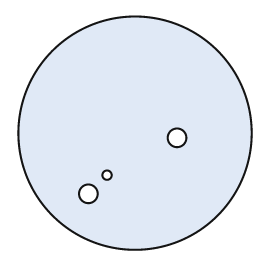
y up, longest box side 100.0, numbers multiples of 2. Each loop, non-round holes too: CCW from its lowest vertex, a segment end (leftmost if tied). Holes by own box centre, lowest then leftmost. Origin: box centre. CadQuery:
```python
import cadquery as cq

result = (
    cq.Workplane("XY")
    .moveTo(0.0, 0.0)
    .circle(50.0)
    .moveTo(-20.0, -26.0)
    .circle(4.0)
    .moveTo(-12.0, -18.0)
    .circle(2.0)
    .moveTo(18.0, -2.0)
    .circle(4.0)
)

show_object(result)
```